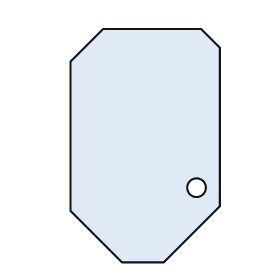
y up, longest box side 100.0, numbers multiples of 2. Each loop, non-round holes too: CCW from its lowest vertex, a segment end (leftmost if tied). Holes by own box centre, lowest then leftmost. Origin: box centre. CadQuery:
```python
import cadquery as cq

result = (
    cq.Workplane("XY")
    .moveTo(-10.0, -50.0)
    .lineTo(8.0, -50.0)
    .lineTo(32.0, -26.0)
    .lineTo(32.0, 42.0)
    .lineTo(24.0, 50.0)
    .lineTo(-18.0, 50.0)
    .lineTo(-32.0, 36.0)
    .lineTo(-32.0, -28.0)
    .close()
    .moveTo(22.0, -18.0)
    .circle(4.0)
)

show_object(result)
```